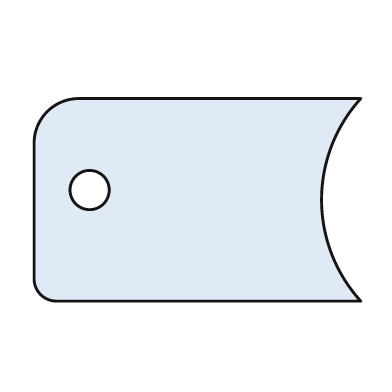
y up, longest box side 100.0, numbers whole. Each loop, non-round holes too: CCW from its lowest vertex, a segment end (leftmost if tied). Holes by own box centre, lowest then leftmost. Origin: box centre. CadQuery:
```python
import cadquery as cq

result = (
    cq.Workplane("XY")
    .moveTo(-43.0, -31.0)
    .lineTo(50.0, -31.0)
    .threePointArc((38.0, 0.0), (50.0, 31.0))
    .lineTo(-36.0, 31.0)
    .threePointArc((-46.0, 27.0), (-50.0, 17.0))
    .lineTo(-50.0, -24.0)
    .threePointArc((-48.0, -29.0), (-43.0, -31.0))
    .close()
    .moveTo(-33.0, 3.0)
    .circle(6.0)
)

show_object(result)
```